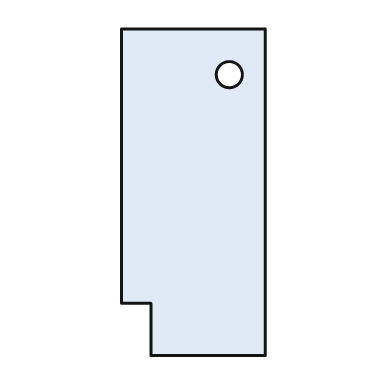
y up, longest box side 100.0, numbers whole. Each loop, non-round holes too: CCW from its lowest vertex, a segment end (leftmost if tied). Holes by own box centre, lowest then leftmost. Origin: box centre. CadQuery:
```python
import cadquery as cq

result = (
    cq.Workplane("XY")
    .moveTo(-13.0, -50.0)
    .lineTo(22.0, -50.0)
    .lineTo(22.0, 50.0)
    .lineTo(-22.0, 50.0)
    .lineTo(-22.0, -34.0)
    .lineTo(-13.0, -34.0)
    .close()
    .moveTo(11.0, 36.0)
    .circle(4.0)
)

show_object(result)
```